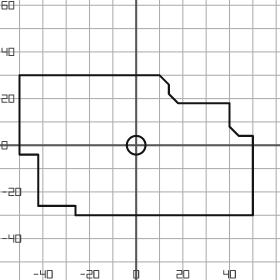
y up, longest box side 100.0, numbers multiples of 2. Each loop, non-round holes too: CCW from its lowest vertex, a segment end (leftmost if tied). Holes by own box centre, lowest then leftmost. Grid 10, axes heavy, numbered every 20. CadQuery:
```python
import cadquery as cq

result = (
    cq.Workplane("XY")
    .moveTo(-26.0, -30.0)
    .lineTo(50.0, -30.0)
    .lineTo(50.0, 4.0)
    .lineTo(44.0, 4.0)
    .lineTo(40.0, 8.0)
    .lineTo(40.0, 18.0)
    .lineTo(18.0, 18.0)
    .lineTo(14.0, 22.0)
    .lineTo(14.0, 26.0)
    .lineTo(10.0, 30.0)
    .lineTo(-50.0, 30.0)
    .lineTo(-50.0, -4.0)
    .lineTo(-42.0, -4.0)
    .lineTo(-42.0, -26.0)
    .lineTo(-26.0, -26.0)
    .close()
    .moveTo(0.0, 0.0)
    .circle(4.0)
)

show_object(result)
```